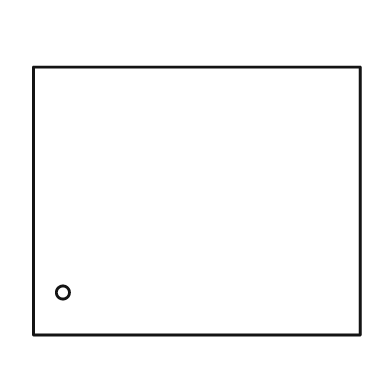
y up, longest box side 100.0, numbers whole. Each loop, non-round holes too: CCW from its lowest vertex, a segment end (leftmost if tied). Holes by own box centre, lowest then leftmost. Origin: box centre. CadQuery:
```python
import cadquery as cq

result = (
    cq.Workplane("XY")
    .moveTo(-50.0, -41.0)
    .lineTo(50.0, -41.0)
    .lineTo(50.0, 41.0)
    .lineTo(-50.0, 41.0)
    .close()
    .moveTo(-41.0, -28.0)
    .circle(2.0)
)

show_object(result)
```